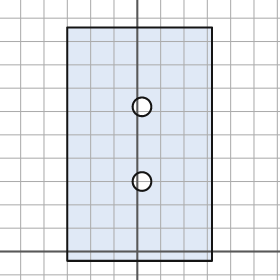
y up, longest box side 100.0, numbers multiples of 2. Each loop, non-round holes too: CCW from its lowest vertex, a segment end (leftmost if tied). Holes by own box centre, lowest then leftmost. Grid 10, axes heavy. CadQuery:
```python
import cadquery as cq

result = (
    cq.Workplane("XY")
    .moveTo(-30.0, -4.0)
    .lineTo(32.0, -4.0)
    .lineTo(32.0, 96.0)
    .lineTo(-30.0, 96.0)
    .close()
    .moveTo(2.0, 30.0)
    .circle(4.0)
    .moveTo(2.0, 62.0)
    .circle(4.0)
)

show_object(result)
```